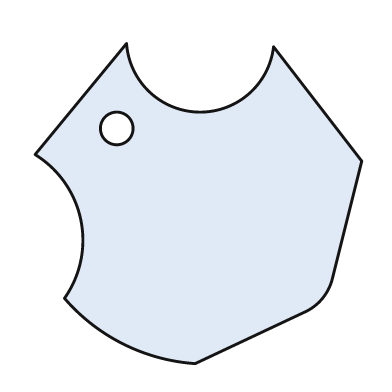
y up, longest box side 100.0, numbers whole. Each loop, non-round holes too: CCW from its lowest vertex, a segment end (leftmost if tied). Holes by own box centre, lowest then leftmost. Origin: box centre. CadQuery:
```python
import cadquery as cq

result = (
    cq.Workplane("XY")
    .moveTo(-1.0, -49.0)
    .lineTo(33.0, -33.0)
    .threePointArc((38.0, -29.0), (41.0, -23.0))
    .lineTo(50.0, 13.0)
    .lineTo(23.0, 48.0)
    .threePointArc((0.0, 28.0), (-22.0, 49.0))
    .lineTo(-50.0, 15.0)
    .threePointArc((-36.0, -5.0), (-41.0, -29.0))
    .threePointArc((-23.0, -43.0), (-1.0, -49.0))
    .close()
    .moveTo(-25.0, 23.0)
    .circle(5.0)
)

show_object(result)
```